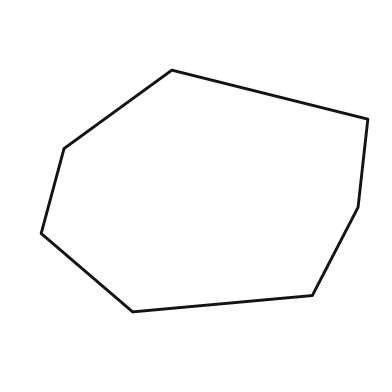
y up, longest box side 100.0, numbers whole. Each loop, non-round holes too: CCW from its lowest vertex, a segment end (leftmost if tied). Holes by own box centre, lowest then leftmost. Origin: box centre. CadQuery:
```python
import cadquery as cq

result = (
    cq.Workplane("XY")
    .moveTo(-22.0, -37.0)
    .lineTo(33.0, -32.0)
    .lineTo(47.0, -5.0)
    .lineTo(50.0, 22.0)
    .lineTo(-10.0, 37.0)
    .lineTo(-43.0, 13.0)
    .lineTo(-50.0, -13.0)
    .close()
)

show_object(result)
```